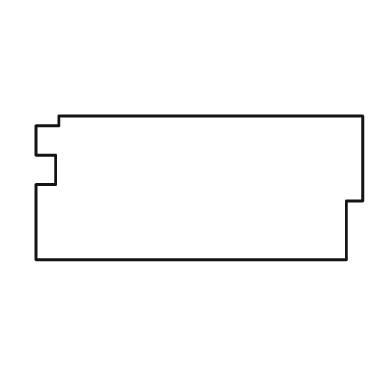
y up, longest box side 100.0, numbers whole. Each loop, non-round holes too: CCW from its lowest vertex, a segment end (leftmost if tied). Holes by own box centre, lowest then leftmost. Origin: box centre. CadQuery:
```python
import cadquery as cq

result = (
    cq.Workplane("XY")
    .moveTo(-50.0, -22.0)
    .lineTo(45.0, -22.0)
    .lineTo(45.0, -4.0)
    .lineTo(50.0, -4.0)
    .lineTo(50.0, 22.0)
    .lineTo(-43.0, 22.0)
    .lineTo(-43.0, 19.0)
    .lineTo(-50.0, 19.0)
    .lineTo(-50.0, 10.0)
    .lineTo(-44.0, 10.0)
    .lineTo(-44.0, 1.0)
    .lineTo(-50.0, 1.0)
    .close()
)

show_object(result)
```